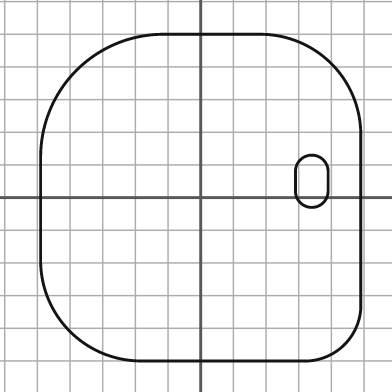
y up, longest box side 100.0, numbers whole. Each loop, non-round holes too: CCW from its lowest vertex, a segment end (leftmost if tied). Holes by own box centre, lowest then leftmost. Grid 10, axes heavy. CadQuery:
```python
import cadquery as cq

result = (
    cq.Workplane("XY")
    .moveTo(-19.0, -50.0)
    .lineTo(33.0, -50.0)
    .threePointArc((44.0, -45.0), (49.0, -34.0))
    .lineTo(49.0, 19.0)
    .threePointArc((40.0, 41.0), (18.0, 50.0))
    .lineTo(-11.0, 50.0)
    .threePointArc((-38.0, 39.0), (-49.0, 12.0))
    .lineTo(-49.0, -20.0)
    .threePointArc((-40.0, -41.0), (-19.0, -50.0))
    .close()
    .moveTo(29.0, 2.0)
    .threePointArc((34.0, -3.0), (39.0, 2.0))
    .lineTo(39.0, 8.0)
    .threePointArc((34.0, 13.0), (29.0, 8.0))
    .close()
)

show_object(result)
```